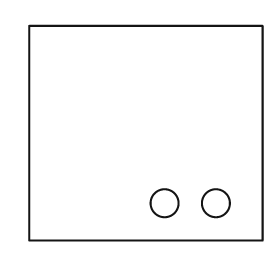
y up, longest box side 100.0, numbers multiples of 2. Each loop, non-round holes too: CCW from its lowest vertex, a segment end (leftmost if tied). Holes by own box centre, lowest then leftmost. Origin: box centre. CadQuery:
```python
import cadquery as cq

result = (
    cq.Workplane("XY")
    .moveTo(-50.0, -46.0)
    .lineTo(50.0, -46.0)
    .lineTo(50.0, 46.0)
    .lineTo(-50.0, 46.0)
    .close()
    .moveTo(8.0, -30.0)
    .circle(6.0)
    .moveTo(30.0, -30.0)
    .circle(6.0)
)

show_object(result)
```